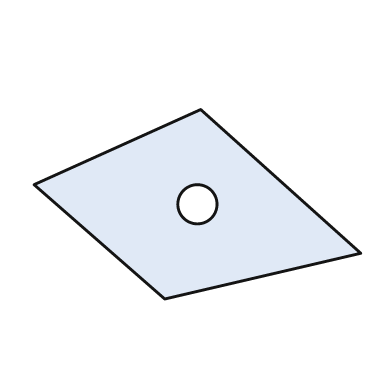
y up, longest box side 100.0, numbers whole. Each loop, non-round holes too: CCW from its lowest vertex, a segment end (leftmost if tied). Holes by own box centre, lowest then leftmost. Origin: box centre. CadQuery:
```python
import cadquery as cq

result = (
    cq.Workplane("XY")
    .moveTo(-10.0, -29.0)
    .lineTo(50.0, -15.0)
    .lineTo(1.0, 29.0)
    .lineTo(-50.0, 6.0)
    .close()
    .moveTo(0.0, 0.0)
    .circle(6.0)
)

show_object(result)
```